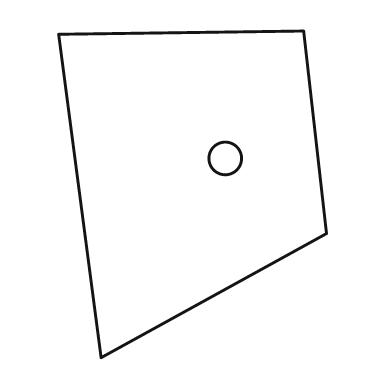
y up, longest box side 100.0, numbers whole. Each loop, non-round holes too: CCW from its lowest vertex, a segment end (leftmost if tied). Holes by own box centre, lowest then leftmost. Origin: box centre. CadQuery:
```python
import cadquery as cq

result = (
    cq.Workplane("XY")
    .moveTo(-28.0, -50.0)
    .lineTo(41.0, -12.0)
    .lineTo(34.0, 50.0)
    .lineTo(-41.0, 49.0)
    .close()
    .moveTo(10.0, 11.0)
    .circle(5.0)
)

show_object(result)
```